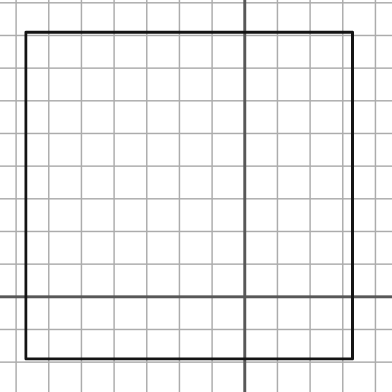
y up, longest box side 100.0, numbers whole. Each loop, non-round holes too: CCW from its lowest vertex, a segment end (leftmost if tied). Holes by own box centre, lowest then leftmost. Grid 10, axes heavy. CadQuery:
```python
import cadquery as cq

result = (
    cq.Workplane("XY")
    .moveTo(-67.0, -19.0)
    .lineTo(33.0, -19.0)
    .lineTo(33.0, 81.0)
    .lineTo(-67.0, 81.0)
    .close()
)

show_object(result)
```